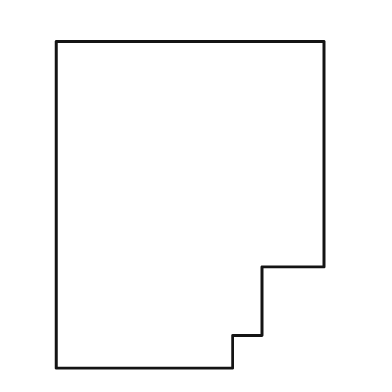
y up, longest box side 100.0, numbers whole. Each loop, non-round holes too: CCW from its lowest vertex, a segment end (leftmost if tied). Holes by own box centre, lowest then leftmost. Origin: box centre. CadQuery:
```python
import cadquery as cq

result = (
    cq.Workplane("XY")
    .moveTo(-41.0, -50.0)
    .lineTo(13.0, -50.0)
    .lineTo(13.0, -40.0)
    .lineTo(22.0, -40.0)
    .lineTo(22.0, -19.0)
    .lineTo(41.0, -19.0)
    .lineTo(41.0, 50.0)
    .lineTo(-41.0, 50.0)
    .close()
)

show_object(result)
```